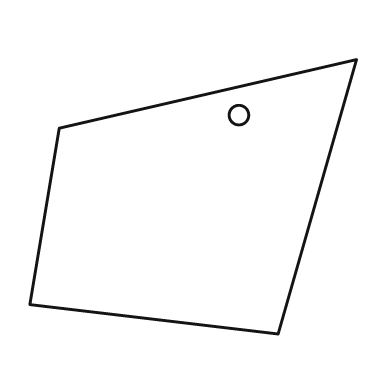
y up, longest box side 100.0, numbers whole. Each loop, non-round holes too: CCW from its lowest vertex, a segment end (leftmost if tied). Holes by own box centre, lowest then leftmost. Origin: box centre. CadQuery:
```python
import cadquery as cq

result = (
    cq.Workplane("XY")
    .moveTo(26.0, -42.0)
    .lineTo(50.0, 42.0)
    .lineTo(-41.0, 21.0)
    .lineTo(-50.0, -33.0)
    .close()
    .moveTo(14.0, 25.0)
    .circle(3.0)
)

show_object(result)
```